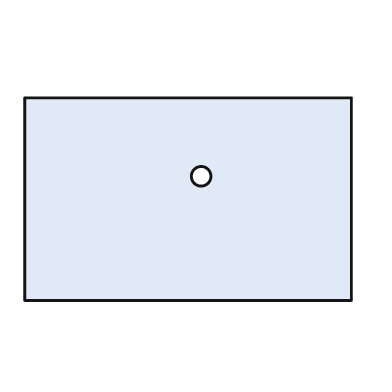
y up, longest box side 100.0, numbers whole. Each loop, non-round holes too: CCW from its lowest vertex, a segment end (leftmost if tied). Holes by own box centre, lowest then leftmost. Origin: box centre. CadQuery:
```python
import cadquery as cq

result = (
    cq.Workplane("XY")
    .moveTo(-50.0, -31.0)
    .lineTo(50.0, -31.0)
    .lineTo(50.0, 31.0)
    .lineTo(-50.0, 31.0)
    .close()
    .moveTo(4.0, 7.0)
    .circle(3.0)
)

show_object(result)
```